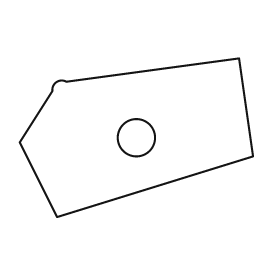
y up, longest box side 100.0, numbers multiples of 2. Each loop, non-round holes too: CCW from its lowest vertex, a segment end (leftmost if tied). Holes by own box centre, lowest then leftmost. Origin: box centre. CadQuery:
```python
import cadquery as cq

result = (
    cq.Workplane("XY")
    .moveTo(-34.0, -34.0)
    .lineTo(50.0, -8.0)
    .lineTo(44.0, 34.0)
    .lineTo(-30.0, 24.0)
    .threePointArc((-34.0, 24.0), (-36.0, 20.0))
    .lineTo(-50.0, -2.0)
    .close()
    .moveTo(0.0, 0.0)
    .circle(8.0)
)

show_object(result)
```